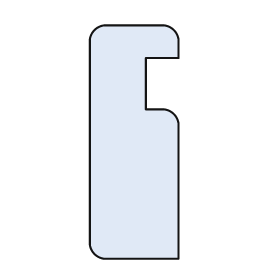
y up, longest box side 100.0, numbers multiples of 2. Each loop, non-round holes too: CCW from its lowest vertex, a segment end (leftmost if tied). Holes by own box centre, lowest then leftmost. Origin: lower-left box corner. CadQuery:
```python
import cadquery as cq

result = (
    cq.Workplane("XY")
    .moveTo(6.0, 0.0)
    .lineTo(38.0, 0.0)
    .lineTo(38.0, 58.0)
    .threePointArc((36.0, 62.0), (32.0, 64.0))
    .lineTo(24.0, 64.0)
    .lineTo(24.0, 86.0)
    .lineTo(38.0, 86.0)
    .lineTo(38.0, 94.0)
    .threePointArc((36.0, 98.0), (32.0, 100.0))
    .lineTo(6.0, 100.0)
    .threePointArc((2.0, 98.0), (0.0, 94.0))
    .lineTo(0.0, 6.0)
    .threePointArc((2.0, 2.0), (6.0, 0.0))
    .close()
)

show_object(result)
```